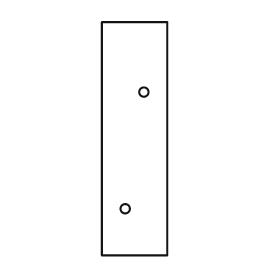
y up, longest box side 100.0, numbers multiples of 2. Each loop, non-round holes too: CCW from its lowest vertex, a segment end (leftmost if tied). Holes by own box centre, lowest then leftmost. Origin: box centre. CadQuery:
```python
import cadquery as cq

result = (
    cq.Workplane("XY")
    .moveTo(-14.0, -50.0)
    .lineTo(14.0, -50.0)
    .lineTo(14.0, 50.0)
    .lineTo(-14.0, 50.0)
    .close()
    .moveTo(-4.0, -30.0)
    .circle(2.0)
    .moveTo(4.0, 20.0)
    .circle(2.0)
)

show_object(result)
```